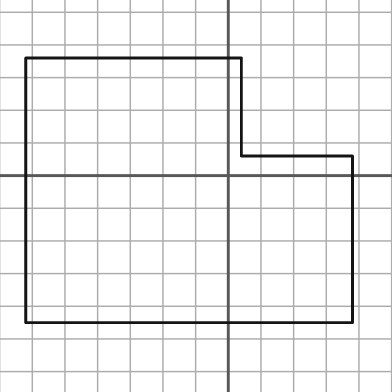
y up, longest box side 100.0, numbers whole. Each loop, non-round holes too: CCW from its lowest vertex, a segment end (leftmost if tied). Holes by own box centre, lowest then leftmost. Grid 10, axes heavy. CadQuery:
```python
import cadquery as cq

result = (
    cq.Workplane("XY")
    .moveTo(-62.0, -45.0)
    .lineTo(38.0, -45.0)
    .lineTo(38.0, 6.0)
    .lineTo(4.0, 6.0)
    .lineTo(4.0, 36.0)
    .lineTo(-62.0, 36.0)
    .close()
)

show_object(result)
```